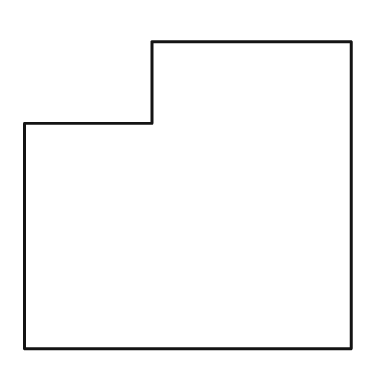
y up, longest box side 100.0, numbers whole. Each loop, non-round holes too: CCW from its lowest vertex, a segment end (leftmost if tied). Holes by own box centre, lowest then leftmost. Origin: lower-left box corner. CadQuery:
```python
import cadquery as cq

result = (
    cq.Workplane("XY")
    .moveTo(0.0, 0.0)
    .lineTo(100.0, 0.0)
    .lineTo(100.0, 94.0)
    .lineTo(39.0, 94.0)
    .lineTo(39.0, 69.0)
    .lineTo(0.0, 69.0)
    .close()
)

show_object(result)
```